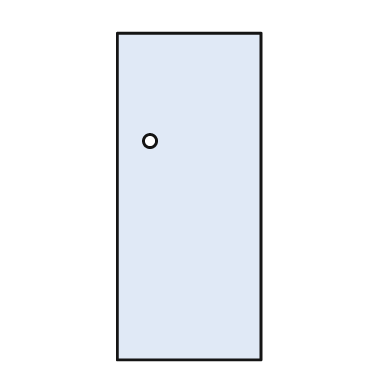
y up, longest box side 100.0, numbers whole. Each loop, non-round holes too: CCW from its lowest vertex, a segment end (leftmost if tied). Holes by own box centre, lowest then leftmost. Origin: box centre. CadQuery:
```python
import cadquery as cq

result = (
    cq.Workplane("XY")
    .moveTo(-22.0, -50.0)
    .lineTo(22.0, -50.0)
    .lineTo(22.0, 50.0)
    .lineTo(-22.0, 50.0)
    .close()
    .moveTo(-12.0, 17.0)
    .circle(2.0)
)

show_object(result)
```